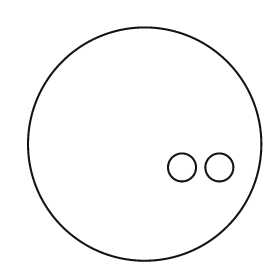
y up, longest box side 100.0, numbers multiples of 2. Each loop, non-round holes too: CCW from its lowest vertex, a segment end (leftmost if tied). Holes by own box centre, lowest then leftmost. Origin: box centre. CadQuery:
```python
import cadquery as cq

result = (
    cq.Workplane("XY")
    .moveTo(0.0, 0.0)
    .circle(50.0)
    .moveTo(16.0, -10.0)
    .circle(6.0)
    .moveTo(32.0, -10.0)
    .circle(6.0)
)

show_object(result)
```